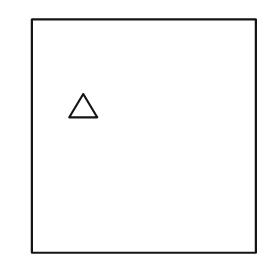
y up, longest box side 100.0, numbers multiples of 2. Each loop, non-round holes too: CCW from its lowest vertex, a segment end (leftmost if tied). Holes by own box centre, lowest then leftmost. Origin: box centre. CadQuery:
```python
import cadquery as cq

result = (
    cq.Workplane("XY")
    .moveTo(-48.0, -50.0)
    .lineTo(48.0, -50.0)
    .lineTo(48.0, 50.0)
    .lineTo(-48.0, 50.0)
    .close()
    .moveTo(-32.0, 8.0)
    .lineTo(-20.0, 8.0)
    .lineTo(-26.0, 18.0)
    .close()
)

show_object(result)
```